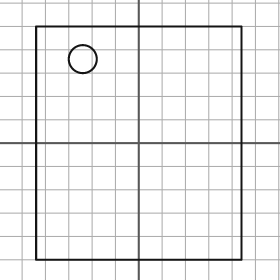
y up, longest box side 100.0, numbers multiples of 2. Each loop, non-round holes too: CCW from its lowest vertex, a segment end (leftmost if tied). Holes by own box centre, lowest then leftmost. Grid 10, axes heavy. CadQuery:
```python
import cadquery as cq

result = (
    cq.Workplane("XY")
    .moveTo(-44.0, -50.0)
    .lineTo(44.0, -50.0)
    .lineTo(44.0, 50.0)
    .lineTo(-44.0, 50.0)
    .close()
    .moveTo(-24.0, 36.0)
    .circle(6.0)
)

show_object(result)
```